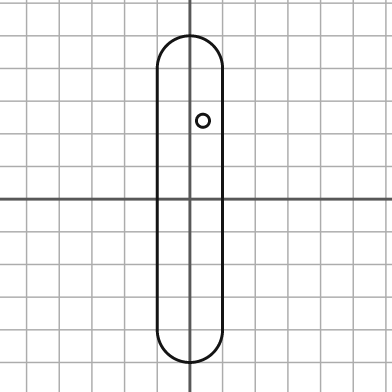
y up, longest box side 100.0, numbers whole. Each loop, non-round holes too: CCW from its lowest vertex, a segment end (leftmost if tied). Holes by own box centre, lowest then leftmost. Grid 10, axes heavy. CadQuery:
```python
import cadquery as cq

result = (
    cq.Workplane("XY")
    .moveTo(-10.0, -40.0)
    .threePointArc((0.0, -50.0), (10.0, -40.0))
    .lineTo(10.0, 40.0)
    .threePointArc((0.0, 50.0), (-10.0, 40.0))
    .close()
    .moveTo(4.0, 24.0)
    .circle(2.0)
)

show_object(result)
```